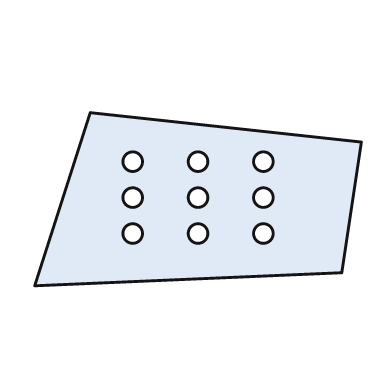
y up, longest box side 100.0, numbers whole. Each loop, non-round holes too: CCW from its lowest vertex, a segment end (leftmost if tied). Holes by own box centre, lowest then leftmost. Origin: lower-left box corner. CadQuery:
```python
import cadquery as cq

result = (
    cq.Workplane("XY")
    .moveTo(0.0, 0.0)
    .lineTo(94.0, 4.0)
    .lineTo(100.0, 44.0)
    .lineTo(17.0, 53.0)
    .close()
    .moveTo(30.0, 16.0)
    .circle(3.0)
    .moveTo(50.0, 16.0)
    .circle(3.0)
    .moveTo(70.0, 16.0)
    .circle(3.0)
    .moveTo(30.0, 27.0)
    .circle(3.0)
    .moveTo(50.0, 27.0)
    .circle(3.0)
    .moveTo(70.0, 27.0)
    .circle(3.0)
    .moveTo(30.0, 38.0)
    .circle(3.0)
    .moveTo(50.0, 38.0)
    .circle(3.0)
    .moveTo(70.0, 38.0)
    .circle(3.0)
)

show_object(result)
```